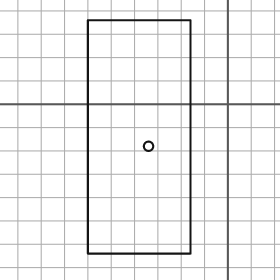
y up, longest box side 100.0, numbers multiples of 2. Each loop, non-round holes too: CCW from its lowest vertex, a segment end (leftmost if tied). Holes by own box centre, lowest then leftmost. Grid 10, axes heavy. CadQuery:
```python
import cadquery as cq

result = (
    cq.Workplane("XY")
    .moveTo(-60.0, -64.0)
    .lineTo(-16.0, -64.0)
    .lineTo(-16.0, 36.0)
    .lineTo(-60.0, 36.0)
    .close()
    .moveTo(-34.0, -18.0)
    .circle(2.0)
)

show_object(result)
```